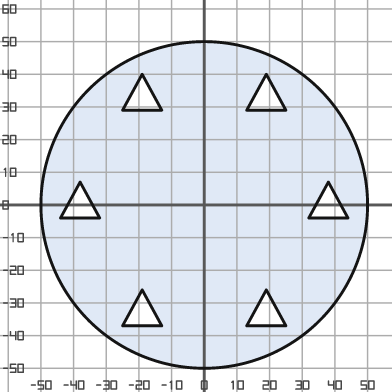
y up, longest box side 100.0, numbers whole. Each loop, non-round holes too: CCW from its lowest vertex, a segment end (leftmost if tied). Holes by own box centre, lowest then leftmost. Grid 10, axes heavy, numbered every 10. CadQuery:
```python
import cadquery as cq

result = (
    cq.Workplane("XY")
    .moveTo(0.0, 0.0)
    .circle(50.0)
    .moveTo(-25.0, -37.0)
    .lineTo(-13.0, -37.0)
    .lineTo(-19.0, -26.0)
    .close()
    .moveTo(13.0, -37.0)
    .lineTo(25.0, -37.0)
    .lineTo(19.0, -26.0)
    .close()
    .moveTo(-44.0, -4.0)
    .lineTo(-32.0, -4.0)
    .lineTo(-38.0, 7.0)
    .close()
    .moveTo(32.0, -4.0)
    .lineTo(44.0, -4.0)
    .lineTo(38.0, 7.0)
    .close()
    .moveTo(-25.0, 29.0)
    .lineTo(-13.0, 29.0)
    .lineTo(-19.0, 40.0)
    .close()
    .moveTo(13.0, 29.0)
    .lineTo(25.0, 29.0)
    .lineTo(19.0, 40.0)
    .close()
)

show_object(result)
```